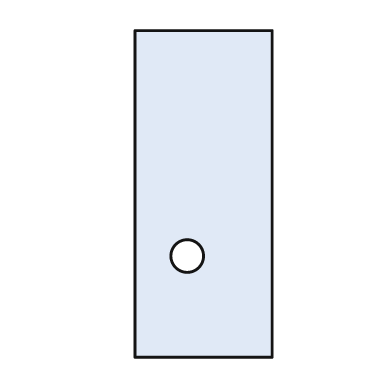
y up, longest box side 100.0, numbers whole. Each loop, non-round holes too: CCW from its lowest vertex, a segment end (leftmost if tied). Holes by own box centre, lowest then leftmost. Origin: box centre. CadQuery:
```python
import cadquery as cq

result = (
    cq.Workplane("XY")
    .moveTo(-21.0, -50.0)
    .lineTo(21.0, -50.0)
    .lineTo(21.0, 50.0)
    .lineTo(-21.0, 50.0)
    .close()
    .moveTo(-5.0, -19.0)
    .circle(5.0)
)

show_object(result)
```